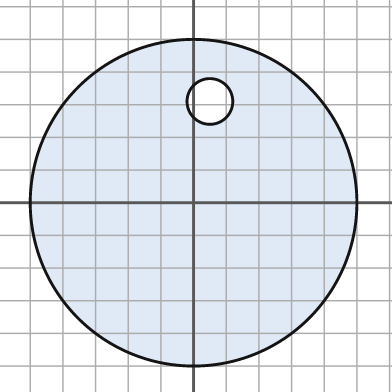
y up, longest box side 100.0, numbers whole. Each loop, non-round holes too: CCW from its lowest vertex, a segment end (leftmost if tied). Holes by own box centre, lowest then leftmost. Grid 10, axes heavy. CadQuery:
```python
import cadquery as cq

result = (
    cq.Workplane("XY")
    .moveTo(0.0, 0.0)
    .circle(50.0)
    .moveTo(5.0, 31.0)
    .circle(7.0)
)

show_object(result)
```